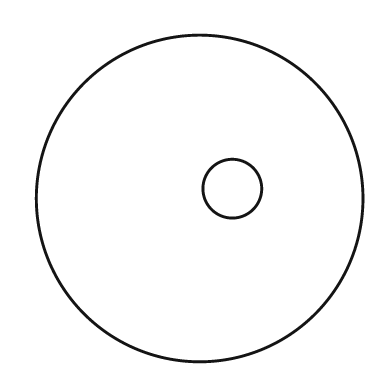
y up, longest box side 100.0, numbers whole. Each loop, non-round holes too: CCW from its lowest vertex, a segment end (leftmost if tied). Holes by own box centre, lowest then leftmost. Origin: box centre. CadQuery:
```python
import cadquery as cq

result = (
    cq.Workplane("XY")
    .moveTo(0.0, 0.0)
    .circle(50.0)
    .moveTo(10.0, 3.0)
    .circle(9.0)
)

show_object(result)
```